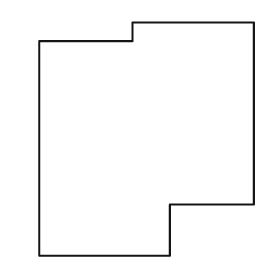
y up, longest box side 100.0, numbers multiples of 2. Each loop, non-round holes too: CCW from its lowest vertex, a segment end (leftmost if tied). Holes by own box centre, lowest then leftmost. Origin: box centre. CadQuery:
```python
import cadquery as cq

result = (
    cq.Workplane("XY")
    .moveTo(-46.0, -50.0)
    .lineTo(10.0, -50.0)
    .lineTo(10.0, -28.0)
    .lineTo(46.0, -28.0)
    .lineTo(46.0, 50.0)
    .lineTo(-6.0, 50.0)
    .lineTo(-6.0, 42.0)
    .lineTo(-46.0, 42.0)
    .close()
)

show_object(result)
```